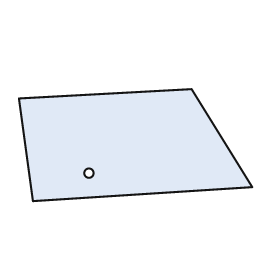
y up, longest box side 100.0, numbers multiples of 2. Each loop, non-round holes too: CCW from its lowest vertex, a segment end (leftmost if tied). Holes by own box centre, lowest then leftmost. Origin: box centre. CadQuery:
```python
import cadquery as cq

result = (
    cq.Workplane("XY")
    .moveTo(-44.0, -24.0)
    .lineTo(50.0, -18.0)
    .lineTo(24.0, 24.0)
    .lineTo(-50.0, 20.0)
    .close()
    .moveTo(-20.0, -12.0)
    .circle(2.0)
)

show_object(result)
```